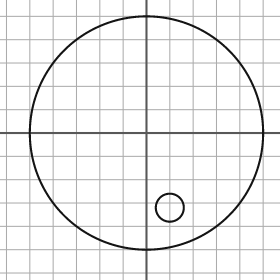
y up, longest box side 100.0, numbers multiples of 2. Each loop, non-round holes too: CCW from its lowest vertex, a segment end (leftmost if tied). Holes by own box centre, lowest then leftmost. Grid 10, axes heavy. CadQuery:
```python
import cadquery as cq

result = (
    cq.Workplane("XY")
    .moveTo(0.0, 0.0)
    .circle(50.0)
    .moveTo(10.0, -32.0)
    .circle(6.0)
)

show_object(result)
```